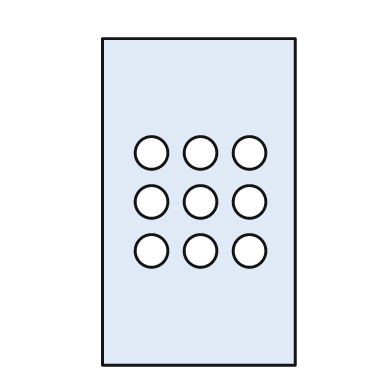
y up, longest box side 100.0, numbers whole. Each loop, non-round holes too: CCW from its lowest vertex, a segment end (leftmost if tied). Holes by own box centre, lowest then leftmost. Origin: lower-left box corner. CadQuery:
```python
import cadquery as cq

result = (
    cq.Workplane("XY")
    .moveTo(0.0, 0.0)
    .lineTo(59.0, 0.0)
    .lineTo(59.0, 100.0)
    .lineTo(0.0, 100.0)
    .close()
    .moveTo(15.0, 35.0)
    .circle(5.0)
    .moveTo(30.0, 35.0)
    .circle(5.0)
    .moveTo(45.0, 35.0)
    .circle(5.0)
    .moveTo(15.0, 50.0)
    .circle(5.0)
    .moveTo(30.0, 50.0)
    .circle(5.0)
    .moveTo(45.0, 50.0)
    .circle(5.0)
    .moveTo(15.0, 65.0)
    .circle(5.0)
    .moveTo(30.0, 65.0)
    .circle(5.0)
    .moveTo(45.0, 65.0)
    .circle(5.0)
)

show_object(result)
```